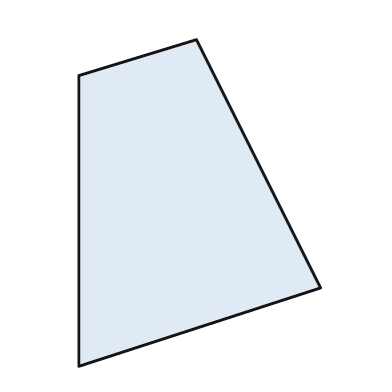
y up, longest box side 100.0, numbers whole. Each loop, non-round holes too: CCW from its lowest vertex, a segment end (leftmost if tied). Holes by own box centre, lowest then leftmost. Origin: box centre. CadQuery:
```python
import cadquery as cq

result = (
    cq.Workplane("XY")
    .moveTo(-37.0, -50.0)
    .lineTo(37.0, -26.0)
    .lineTo(-1.0, 50.0)
    .lineTo(-37.0, 39.0)
    .close()
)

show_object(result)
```